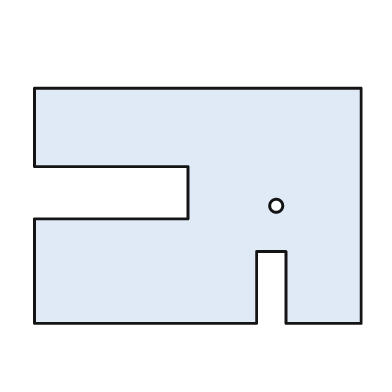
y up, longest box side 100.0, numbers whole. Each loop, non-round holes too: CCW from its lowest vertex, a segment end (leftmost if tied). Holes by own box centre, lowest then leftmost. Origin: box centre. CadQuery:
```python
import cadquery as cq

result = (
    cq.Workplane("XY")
    .moveTo(-50.0, -36.0)
    .lineTo(18.0, -36.0)
    .lineTo(18.0, -14.0)
    .lineTo(27.0, -14.0)
    .lineTo(27.0, -36.0)
    .lineTo(50.0, -36.0)
    .lineTo(50.0, 36.0)
    .lineTo(-50.0, 36.0)
    .lineTo(-50.0, 12.0)
    .lineTo(-3.0, 12.0)
    .lineTo(-3.0, -4.0)
    .lineTo(-50.0, -4.0)
    .close()
    .moveTo(24.0, 0.0)
    .circle(2.0)
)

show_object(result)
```